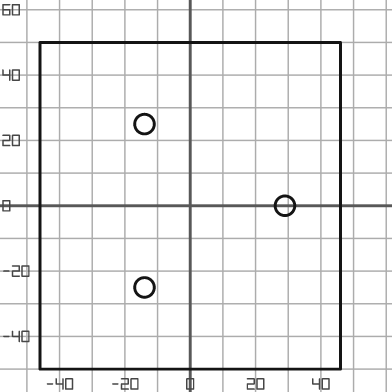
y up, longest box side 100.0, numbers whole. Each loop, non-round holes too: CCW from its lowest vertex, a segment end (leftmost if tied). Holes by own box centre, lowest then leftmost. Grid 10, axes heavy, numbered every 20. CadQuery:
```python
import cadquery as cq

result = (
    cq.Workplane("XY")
    .moveTo(-46.0, -50.0)
    .lineTo(46.0, -50.0)
    .lineTo(46.0, 50.0)
    .lineTo(-46.0, 50.0)
    .close()
    .moveTo(-14.0, -25.0)
    .circle(3.0)
    .moveTo(29.0, 0.0)
    .circle(3.0)
    .moveTo(-14.0, 25.0)
    .circle(3.0)
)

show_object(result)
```